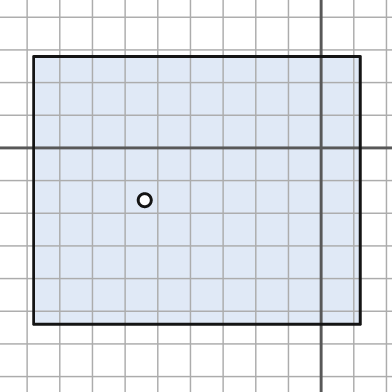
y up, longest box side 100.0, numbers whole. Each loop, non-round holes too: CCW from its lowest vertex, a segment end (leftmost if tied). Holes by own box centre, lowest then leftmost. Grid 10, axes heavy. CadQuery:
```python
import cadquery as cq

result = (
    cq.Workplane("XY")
    .moveTo(-88.0, -54.0)
    .lineTo(12.0, -54.0)
    .lineTo(12.0, 28.0)
    .lineTo(-88.0, 28.0)
    .close()
    .moveTo(-54.0, -16.0)
    .circle(2.0)
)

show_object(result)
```